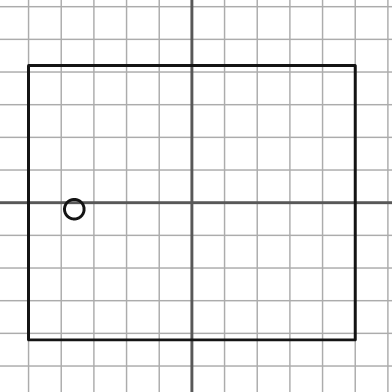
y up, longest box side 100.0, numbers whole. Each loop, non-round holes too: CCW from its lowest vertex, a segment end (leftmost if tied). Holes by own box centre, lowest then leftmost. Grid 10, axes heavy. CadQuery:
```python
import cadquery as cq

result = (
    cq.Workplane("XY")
    .moveTo(-50.0, -42.0)
    .lineTo(50.0, -42.0)
    .lineTo(50.0, 42.0)
    .lineTo(-50.0, 42.0)
    .close()
    .moveTo(-36.0, -2.0)
    .circle(3.0)
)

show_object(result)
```